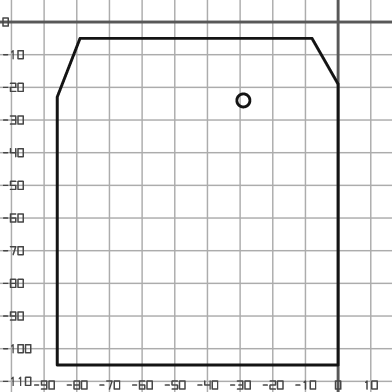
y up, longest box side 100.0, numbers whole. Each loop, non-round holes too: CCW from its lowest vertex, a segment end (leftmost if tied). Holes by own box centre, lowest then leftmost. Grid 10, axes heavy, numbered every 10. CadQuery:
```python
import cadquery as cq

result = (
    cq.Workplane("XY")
    .moveTo(-86.0, -105.0)
    .lineTo(0.0, -105.0)
    .lineTo(0.0, -19.0)
    .lineTo(-8.0, -5.0)
    .lineTo(-79.0, -5.0)
    .lineTo(-86.0, -23.0)
    .close()
    .moveTo(-29.0, -24.0)
    .circle(2.0)
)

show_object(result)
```